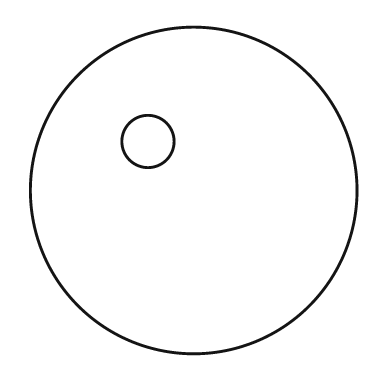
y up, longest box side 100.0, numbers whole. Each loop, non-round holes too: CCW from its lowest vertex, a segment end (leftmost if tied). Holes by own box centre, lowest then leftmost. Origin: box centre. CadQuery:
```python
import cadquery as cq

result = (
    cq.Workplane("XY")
    .moveTo(0.0, 0.0)
    .circle(50.0)
    .moveTo(-14.0, 15.0)
    .circle(8.0)
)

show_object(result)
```